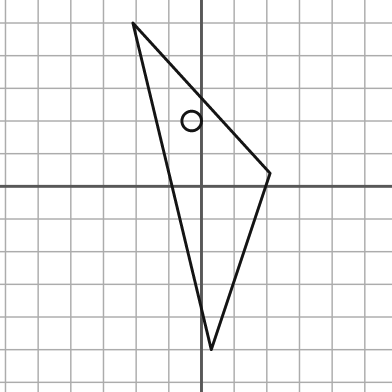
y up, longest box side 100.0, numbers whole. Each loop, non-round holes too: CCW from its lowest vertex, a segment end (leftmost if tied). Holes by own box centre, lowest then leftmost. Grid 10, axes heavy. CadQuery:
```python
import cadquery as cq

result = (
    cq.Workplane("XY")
    .moveTo(3.0, -50.0)
    .lineTo(21.0, 4.0)
    .lineTo(-21.0, 50.0)
    .close()
    .moveTo(-3.0, 20.0)
    .circle(3.0)
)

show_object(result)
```